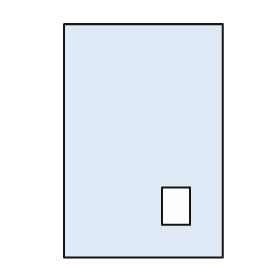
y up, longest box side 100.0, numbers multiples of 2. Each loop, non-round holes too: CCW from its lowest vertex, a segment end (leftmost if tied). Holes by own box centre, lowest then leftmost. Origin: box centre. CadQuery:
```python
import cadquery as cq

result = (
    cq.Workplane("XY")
    .moveTo(-34.0, -50.0)
    .lineTo(34.0, -50.0)
    .lineTo(34.0, 50.0)
    .lineTo(-34.0, 50.0)
    .close()
    .moveTo(8.0, -36.0)
    .lineTo(20.0, -36.0)
    .lineTo(20.0, -20.0)
    .lineTo(8.0, -20.0)
    .close()
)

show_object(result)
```